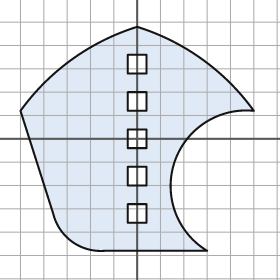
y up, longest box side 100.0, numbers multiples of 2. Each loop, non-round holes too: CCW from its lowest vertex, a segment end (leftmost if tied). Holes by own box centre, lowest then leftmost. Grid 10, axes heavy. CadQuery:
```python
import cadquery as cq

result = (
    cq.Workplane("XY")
    .moveTo(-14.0, -48.0)
    .lineTo(30.0, -48.0)
    .threePointArc((16.0, -10.0), (50.0, 12.0))
    .threePointArc((28.0, 34.0), (0.0, 48.0))
    .threePointArc((-28.0, 34.0), (-50.0, 12.0))
    .lineTo(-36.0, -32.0)
    .threePointArc((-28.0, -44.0), (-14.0, -48.0))
    .close()
    .moveTo(-4.0, -36.0)
    .lineTo(4.0, -36.0)
    .lineTo(4.0, -28.0)
    .lineTo(-4.0, -28.0)
    .close()
    .moveTo(-4.0, -20.0)
    .lineTo(4.0, -20.0)
    .lineTo(4.0, -12.0)
    .lineTo(-4.0, -12.0)
    .close()
    .moveTo(-4.0, -4.0)
    .lineTo(4.0, -4.0)
    .lineTo(4.0, 4.0)
    .lineTo(-4.0, 4.0)
    .close()
    .moveTo(-4.0, 12.0)
    .lineTo(4.0, 12.0)
    .lineTo(4.0, 20.0)
    .lineTo(-4.0, 20.0)
    .close()
    .moveTo(-4.0, 28.0)
    .lineTo(4.0, 28.0)
    .lineTo(4.0, 36.0)
    .lineTo(-4.0, 36.0)
    .close()
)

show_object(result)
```